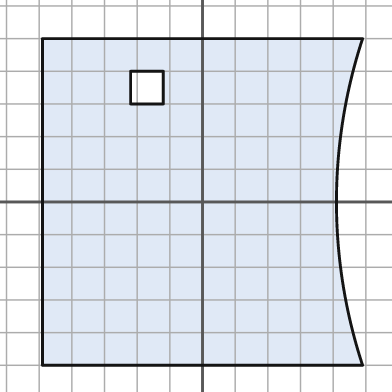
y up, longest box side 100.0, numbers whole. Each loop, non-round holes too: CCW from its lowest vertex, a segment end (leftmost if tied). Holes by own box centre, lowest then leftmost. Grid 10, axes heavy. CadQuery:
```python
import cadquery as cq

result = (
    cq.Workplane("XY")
    .moveTo(-49.0, -50.0)
    .lineTo(49.0, -50.0)
    .threePointArc((41.0, 0.0), (49.0, 50.0))
    .lineTo(-49.0, 50.0)
    .close()
    .moveTo(-22.0, 30.0)
    .lineTo(-12.0, 30.0)
    .lineTo(-12.0, 40.0)
    .lineTo(-22.0, 40.0)
    .close()
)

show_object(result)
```